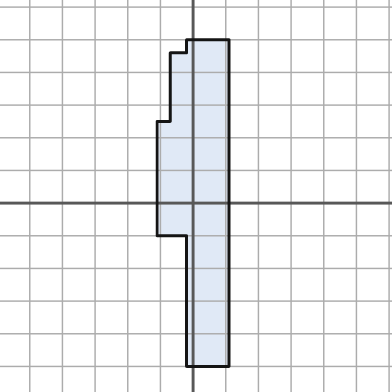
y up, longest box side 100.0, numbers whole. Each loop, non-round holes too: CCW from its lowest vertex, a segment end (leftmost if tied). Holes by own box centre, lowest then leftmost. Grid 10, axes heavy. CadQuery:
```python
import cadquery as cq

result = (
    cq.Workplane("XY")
    .moveTo(-2.0, -50.0)
    .lineTo(11.0, -50.0)
    .lineTo(11.0, 50.0)
    .lineTo(-2.0, 50.0)
    .lineTo(-2.0, 46.0)
    .lineTo(-7.0, 46.0)
    .lineTo(-7.0, 25.0)
    .lineTo(-11.0, 25.0)
    .lineTo(-11.0, -10.0)
    .lineTo(-2.0, -10.0)
    .close()
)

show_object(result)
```